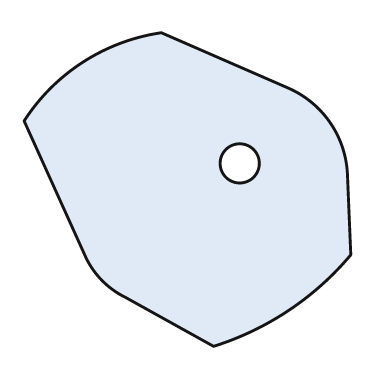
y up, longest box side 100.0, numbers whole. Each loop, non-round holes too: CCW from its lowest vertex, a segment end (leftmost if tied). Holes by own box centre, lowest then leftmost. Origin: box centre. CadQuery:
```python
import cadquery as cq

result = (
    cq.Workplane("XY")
    .moveTo(8.0, -48.0)
    .threePointArc((31.0, -37.0), (50.0, -20.0))
    .lineTo(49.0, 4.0)
    .threePointArc((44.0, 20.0), (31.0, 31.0))
    .lineTo(-8.0, 48.0)
    .threePointArc((-32.0, 39.0), (-50.0, 21.0))
    .lineTo(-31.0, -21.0)
    .threePointArc((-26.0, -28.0), (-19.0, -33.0))
    .close()
    .moveTo(16.0, 8.0)
    .circle(6.0)
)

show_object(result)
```